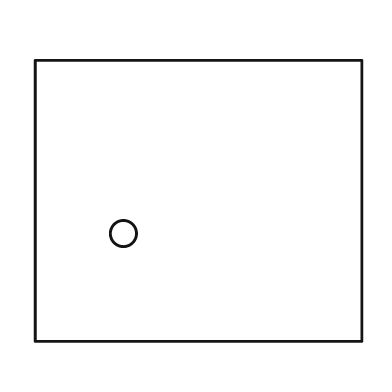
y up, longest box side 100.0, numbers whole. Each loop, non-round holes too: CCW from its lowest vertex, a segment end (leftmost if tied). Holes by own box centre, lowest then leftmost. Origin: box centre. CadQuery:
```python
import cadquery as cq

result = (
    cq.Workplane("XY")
    .moveTo(-50.0, -43.0)
    .lineTo(50.0, -43.0)
    .lineTo(50.0, 43.0)
    .lineTo(-50.0, 43.0)
    .close()
    .moveTo(-23.0, -10.0)
    .circle(4.0)
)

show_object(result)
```